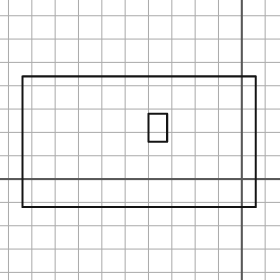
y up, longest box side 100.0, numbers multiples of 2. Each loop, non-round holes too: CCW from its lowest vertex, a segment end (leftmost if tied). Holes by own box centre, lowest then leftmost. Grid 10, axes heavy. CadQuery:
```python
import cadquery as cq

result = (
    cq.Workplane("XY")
    .moveTo(-94.0, -12.0)
    .lineTo(6.0, -12.0)
    .lineTo(6.0, 44.0)
    .lineTo(-94.0, 44.0)
    .close()
    .moveTo(-40.0, 16.0)
    .lineTo(-32.0, 16.0)
    .lineTo(-32.0, 28.0)
    .lineTo(-40.0, 28.0)
    .close()
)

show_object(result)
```